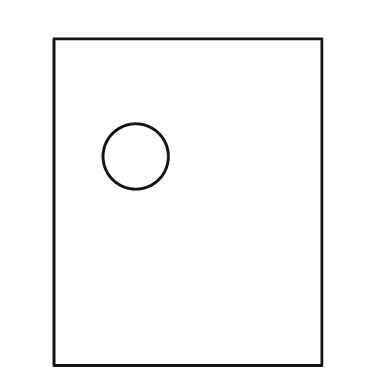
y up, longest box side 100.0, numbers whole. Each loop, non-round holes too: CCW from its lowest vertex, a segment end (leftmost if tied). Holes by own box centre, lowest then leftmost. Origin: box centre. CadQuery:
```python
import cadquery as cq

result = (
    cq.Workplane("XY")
    .moveTo(-41.0, -50.0)
    .lineTo(41.0, -50.0)
    .lineTo(41.0, 50.0)
    .lineTo(-41.0, 50.0)
    .close()
    .moveTo(-16.0, 14.0)
    .circle(10.0)
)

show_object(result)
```